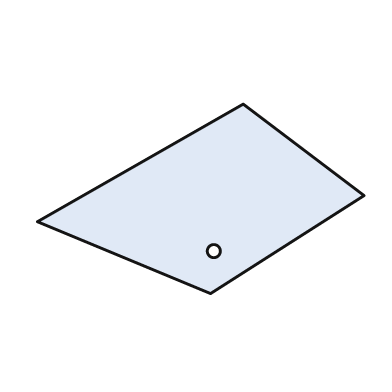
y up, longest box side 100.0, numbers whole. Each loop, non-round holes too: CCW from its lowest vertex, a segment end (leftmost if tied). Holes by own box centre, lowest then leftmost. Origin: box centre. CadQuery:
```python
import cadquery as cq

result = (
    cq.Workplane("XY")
    .moveTo(3.0, -29.0)
    .lineTo(50.0, 1.0)
    .lineTo(13.0, 29.0)
    .lineTo(-50.0, -7.0)
    .close()
    .moveTo(4.0, -16.0)
    .circle(2.0)
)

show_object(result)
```